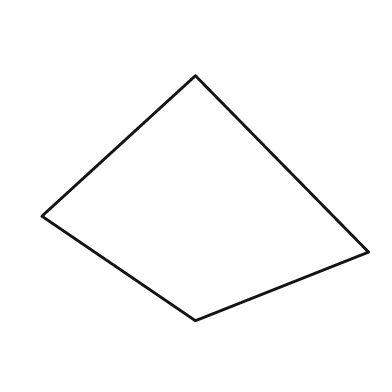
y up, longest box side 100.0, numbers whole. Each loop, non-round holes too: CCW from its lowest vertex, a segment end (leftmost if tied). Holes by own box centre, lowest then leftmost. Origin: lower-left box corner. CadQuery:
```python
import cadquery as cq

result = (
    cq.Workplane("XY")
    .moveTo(47.0, 0.0)
    .lineTo(100.0, 21.0)
    .lineTo(47.0, 75.0)
    .lineTo(0.0, 32.0)
    .close()
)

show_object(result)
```